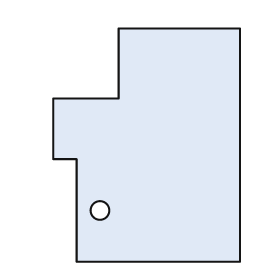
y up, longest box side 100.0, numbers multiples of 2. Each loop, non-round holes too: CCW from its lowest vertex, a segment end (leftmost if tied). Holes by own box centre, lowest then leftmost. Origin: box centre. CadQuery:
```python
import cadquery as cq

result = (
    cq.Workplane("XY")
    .moveTo(-30.0, -50.0)
    .lineTo(40.0, -50.0)
    .lineTo(40.0, 50.0)
    .lineTo(-12.0, 50.0)
    .lineTo(-12.0, 20.0)
    .lineTo(-40.0, 20.0)
    .lineTo(-40.0, -6.0)
    .lineTo(-30.0, -6.0)
    .close()
    .moveTo(-20.0, -28.0)
    .circle(4.0)
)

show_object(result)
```